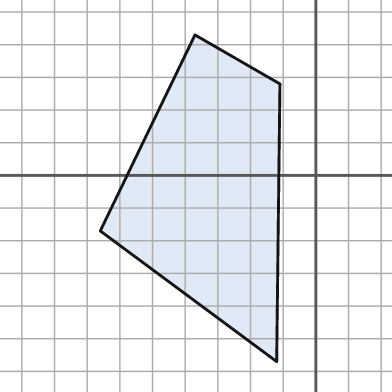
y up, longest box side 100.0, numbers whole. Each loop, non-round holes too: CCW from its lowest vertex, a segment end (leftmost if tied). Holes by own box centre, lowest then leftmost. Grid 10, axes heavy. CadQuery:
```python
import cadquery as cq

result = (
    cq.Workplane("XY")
    .moveTo(-12.0, -57.0)
    .lineTo(-11.0, 28.0)
    .lineTo(-37.0, 43.0)
    .lineTo(-66.0, -17.0)
    .close()
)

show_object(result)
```